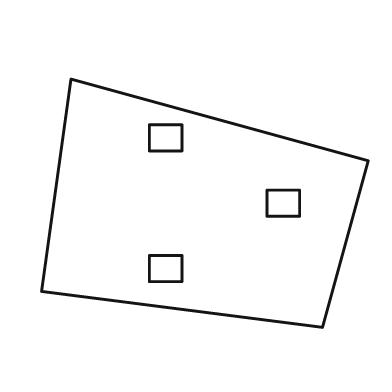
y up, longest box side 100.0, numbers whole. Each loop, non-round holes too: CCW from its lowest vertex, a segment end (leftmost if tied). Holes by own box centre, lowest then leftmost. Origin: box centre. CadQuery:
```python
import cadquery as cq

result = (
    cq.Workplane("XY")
    .moveTo(36.0, -38.0)
    .lineTo(50.0, 13.0)
    .lineTo(-41.0, 38.0)
    .lineTo(-50.0, -27.0)
    .close()
    .moveTo(-17.0, -24.0)
    .lineTo(-7.0, -24.0)
    .lineTo(-7.0, -16.0)
    .lineTo(-17.0, -16.0)
    .close()
    .moveTo(19.0, -4.0)
    .lineTo(29.0, -4.0)
    .lineTo(29.0, 4.0)
    .lineTo(19.0, 4.0)
    .close()
    .moveTo(-17.0, 16.0)
    .lineTo(-7.0, 16.0)
    .lineTo(-7.0, 24.0)
    .lineTo(-17.0, 24.0)
    .close()
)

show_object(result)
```